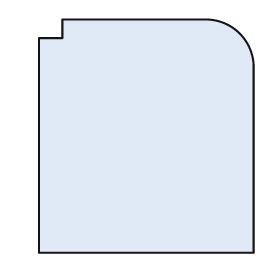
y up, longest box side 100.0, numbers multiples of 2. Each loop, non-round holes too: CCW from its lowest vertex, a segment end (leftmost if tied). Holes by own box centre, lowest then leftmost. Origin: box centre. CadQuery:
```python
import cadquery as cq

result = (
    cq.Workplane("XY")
    .moveTo(-46.0, -50.0)
    .lineTo(46.0, -50.0)
    .lineTo(46.0, 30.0)
    .threePointArc((40.0, 44.0), (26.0, 50.0))
    .lineTo(-36.0, 50.0)
    .lineTo(-36.0, 42.0)
    .lineTo(-46.0, 42.0)
    .close()
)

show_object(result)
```